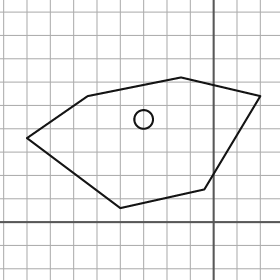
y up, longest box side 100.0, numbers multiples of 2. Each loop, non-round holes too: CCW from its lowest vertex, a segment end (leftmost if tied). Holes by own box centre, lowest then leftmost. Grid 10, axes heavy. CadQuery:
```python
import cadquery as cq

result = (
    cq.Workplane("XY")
    .moveTo(-40.0, 6.0)
    .lineTo(-4.0, 14.0)
    .lineTo(20.0, 54.0)
    .lineTo(-14.0, 62.0)
    .lineTo(-54.0, 54.0)
    .lineTo(-80.0, 36.0)
    .close()
    .moveTo(-30.0, 44.0)
    .circle(4.0)
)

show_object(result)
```